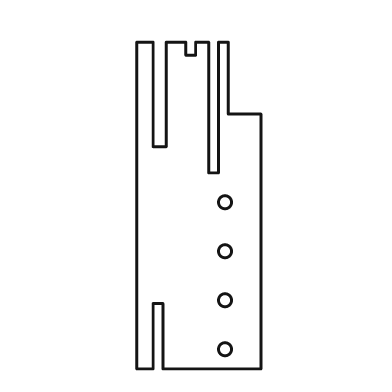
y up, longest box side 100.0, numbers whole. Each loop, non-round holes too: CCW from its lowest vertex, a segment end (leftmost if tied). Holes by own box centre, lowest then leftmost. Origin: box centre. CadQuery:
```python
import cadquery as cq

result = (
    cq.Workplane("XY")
    .moveTo(-19.0, -50.0)
    .lineTo(-14.0, -50.0)
    .lineTo(-14.0, -30.0)
    .lineTo(-11.0, -30.0)
    .lineTo(-11.0, -50.0)
    .lineTo(19.0, -50.0)
    .lineTo(19.0, 28.0)
    .lineTo(9.0, 28.0)
    .lineTo(9.0, 50.0)
    .lineTo(6.0, 50.0)
    .lineTo(6.0, 10.0)
    .lineTo(3.0, 10.0)
    .lineTo(3.0, 50.0)
    .lineTo(-1.0, 50.0)
    .lineTo(-1.0, 46.0)
    .lineTo(-4.0, 46.0)
    .lineTo(-4.0, 50.0)
    .lineTo(-10.0, 50.0)
    .lineTo(-10.0, 18.0)
    .lineTo(-14.0, 18.0)
    .lineTo(-14.0, 50.0)
    .lineTo(-19.0, 50.0)
    .close()
    .moveTo(8.0, -44.0)
    .circle(2.0)
    .moveTo(8.0, -29.0)
    .circle(2.0)
    .moveTo(8.0, -14.0)
    .circle(2.0)
    .moveTo(8.0, 1.0)
    .circle(2.0)
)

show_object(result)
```